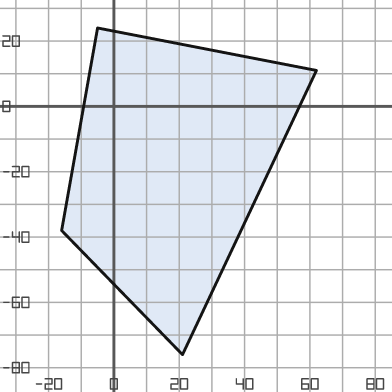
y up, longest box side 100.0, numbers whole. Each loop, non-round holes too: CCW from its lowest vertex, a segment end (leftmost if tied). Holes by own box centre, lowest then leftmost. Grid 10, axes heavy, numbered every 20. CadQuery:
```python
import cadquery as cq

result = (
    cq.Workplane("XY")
    .moveTo(21.0, -76.0)
    .lineTo(62.0, 11.0)
    .lineTo(-5.0, 24.0)
    .lineTo(-16.0, -38.0)
    .close()
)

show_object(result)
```